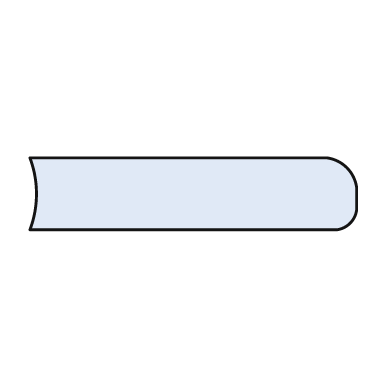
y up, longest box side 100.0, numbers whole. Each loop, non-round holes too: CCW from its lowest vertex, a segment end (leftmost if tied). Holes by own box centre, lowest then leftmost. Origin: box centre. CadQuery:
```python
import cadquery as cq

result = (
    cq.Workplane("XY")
    .moveTo(-50.0, -11.0)
    .lineTo(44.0, -11.0)
    .threePointArc((48.0, -9.0), (50.0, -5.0))
    .lineTo(50.0, 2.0)
    .threePointArc((47.0, 8.0), (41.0, 11.0))
    .lineTo(-50.0, 11.0)
    .threePointArc((-48.0, 0.0), (-50.0, -11.0))
    .close()
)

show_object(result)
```